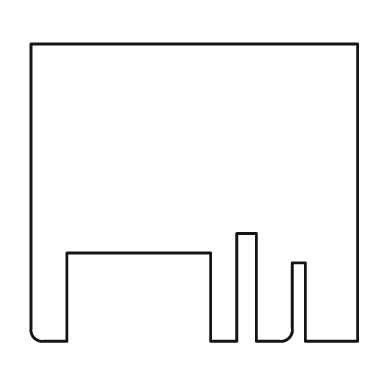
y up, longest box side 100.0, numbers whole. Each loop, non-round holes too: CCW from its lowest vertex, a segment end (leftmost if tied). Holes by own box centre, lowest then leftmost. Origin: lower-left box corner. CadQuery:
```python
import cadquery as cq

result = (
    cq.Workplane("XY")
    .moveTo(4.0, 0.0)
    .lineTo(11.0, 0.0)
    .lineTo(11.0, 27.0)
    .lineTo(55.0, 27.0)
    .lineTo(55.0, 0.0)
    .lineTo(63.0, 0.0)
    .lineTo(63.0, 33.0)
    .lineTo(69.0, 33.0)
    .lineTo(69.0, 0.0)
    .lineTo(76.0, 0.0)
    .threePointArc((79.0, 1.0), (80.0, 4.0))
    .lineTo(80.0, 24.0)
    .lineTo(84.0, 24.0)
    .lineTo(84.0, 0.0)
    .lineTo(100.0, 0.0)
    .lineTo(100.0, 91.0)
    .lineTo(0.0, 91.0)
    .lineTo(0.0, 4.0)
    .threePointArc((1.0, 1.0), (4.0, 0.0))
    .close()
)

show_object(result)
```